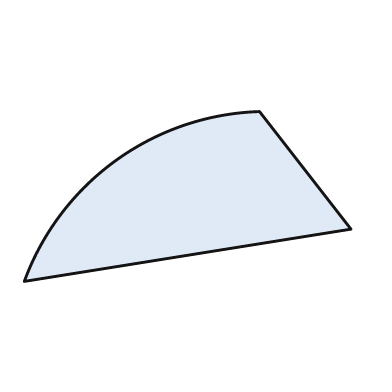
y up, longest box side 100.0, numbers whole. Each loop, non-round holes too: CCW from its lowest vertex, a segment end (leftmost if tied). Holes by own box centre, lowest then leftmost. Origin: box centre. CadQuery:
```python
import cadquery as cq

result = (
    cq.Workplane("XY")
    .moveTo(-50.0, -26.0)
    .lineTo(50.0, -10.0)
    .lineTo(22.0, 26.0)
    .threePointArc((-22.0, 11.0), (-50.0, -26.0))
    .close()
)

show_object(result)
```